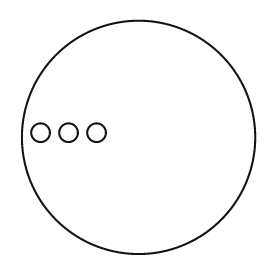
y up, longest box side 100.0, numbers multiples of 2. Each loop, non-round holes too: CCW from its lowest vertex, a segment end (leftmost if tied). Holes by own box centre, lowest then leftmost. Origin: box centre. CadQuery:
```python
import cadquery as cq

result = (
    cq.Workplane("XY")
    .moveTo(0.0, 0.0)
    .circle(50.0)
    .moveTo(-42.0, 2.0)
    .circle(4.0)
    .moveTo(-30.0, 2.0)
    .circle(4.0)
    .moveTo(-18.0, 2.0)
    .circle(4.0)
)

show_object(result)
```